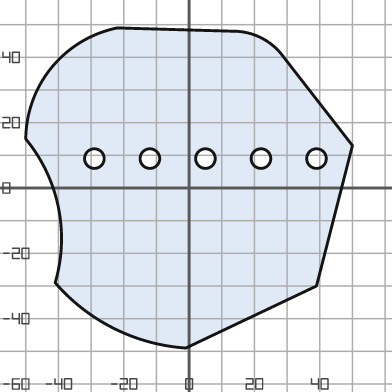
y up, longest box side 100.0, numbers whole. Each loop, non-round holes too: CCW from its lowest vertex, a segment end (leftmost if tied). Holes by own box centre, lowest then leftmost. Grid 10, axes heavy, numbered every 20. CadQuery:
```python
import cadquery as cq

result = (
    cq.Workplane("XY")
    .moveTo(-1.0, -49.0)
    .lineTo(39.0, -30.0)
    .lineTo(50.0, 13.0)
    .lineTo(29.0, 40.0)
    .threePointArc((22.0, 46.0), (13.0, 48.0))
    .lineTo(-22.0, 49.0)
    .threePointArc((-42.0, 37.0), (-50.0, 15.0))
    .threePointArc((-40.0, -6.0), (-41.0, -29.0))
    .threePointArc((-23.0, -43.0), (-1.0, -49.0))
    .close()
    .moveTo(-29.0, 9.0)
    .circle(3.0)
    .moveTo(-12.0, 9.0)
    .circle(3.0)
    .moveTo(5.0, 9.0)
    .circle(3.0)
    .moveTo(22.0, 9.0)
    .circle(3.0)
    .moveTo(39.0, 9.0)
    .circle(3.0)
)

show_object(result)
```